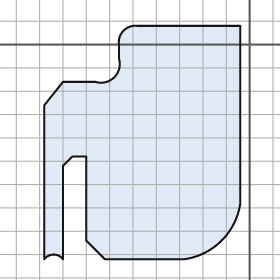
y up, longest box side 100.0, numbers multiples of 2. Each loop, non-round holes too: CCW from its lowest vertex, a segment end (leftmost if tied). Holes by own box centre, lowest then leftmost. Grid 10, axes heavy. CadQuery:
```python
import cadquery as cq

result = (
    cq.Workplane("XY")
    .moveTo(-88.0, -92.0)
    .threePointArc((-84.0, -90.0), (-80.0, -92.0))
    .lineTo(-80.0, -52.0)
    .lineTo(-76.0, -48.0)
    .lineTo(-70.0, -48.0)
    .lineTo(-70.0, -84.0)
    .lineTo(-62.0, -92.0)
    .lineTo(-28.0, -92.0)
    .threePointArc((-12.0, -84.0), (-4.0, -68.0))
    .lineTo(-4.0, 8.0)
    .lineTo(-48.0, 8.0)
    .threePointArc((-54.0, 6.0), (-56.0, 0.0))
    .lineTo(-56.0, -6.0)
    .threePointArc((-58.0, -14.0), (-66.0, -16.0))
    .lineTo(-80.0, -16.0)
    .lineTo(-88.0, -26.0)
    .close()
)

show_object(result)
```